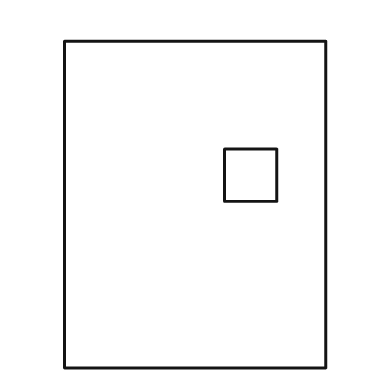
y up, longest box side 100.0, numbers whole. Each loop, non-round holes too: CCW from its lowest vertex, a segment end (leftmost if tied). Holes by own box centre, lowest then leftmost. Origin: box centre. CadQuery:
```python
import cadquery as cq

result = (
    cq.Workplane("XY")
    .moveTo(-40.0, -50.0)
    .lineTo(40.0, -50.0)
    .lineTo(40.0, 50.0)
    .lineTo(-40.0, 50.0)
    .close()
    .moveTo(9.0, 1.0)
    .lineTo(25.0, 1.0)
    .lineTo(25.0, 17.0)
    .lineTo(9.0, 17.0)
    .close()
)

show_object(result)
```